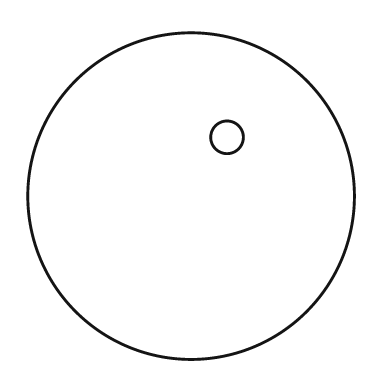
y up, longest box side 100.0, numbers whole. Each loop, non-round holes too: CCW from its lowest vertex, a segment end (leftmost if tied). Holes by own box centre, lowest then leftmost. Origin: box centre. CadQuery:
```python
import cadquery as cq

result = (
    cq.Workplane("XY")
    .moveTo(0.0, 0.0)
    .circle(50.0)
    .moveTo(11.0, 18.0)
    .circle(5.0)
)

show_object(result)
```